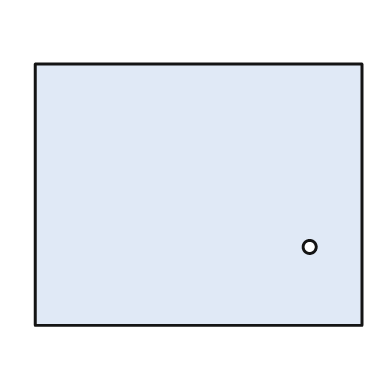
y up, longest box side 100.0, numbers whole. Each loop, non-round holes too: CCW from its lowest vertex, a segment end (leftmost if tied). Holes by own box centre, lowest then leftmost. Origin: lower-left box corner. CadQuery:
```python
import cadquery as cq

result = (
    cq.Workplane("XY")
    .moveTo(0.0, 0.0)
    .lineTo(100.0, 0.0)
    .lineTo(100.0, 80.0)
    .lineTo(0.0, 80.0)
    .close()
    .moveTo(84.0, 24.0)
    .circle(2.0)
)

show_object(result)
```